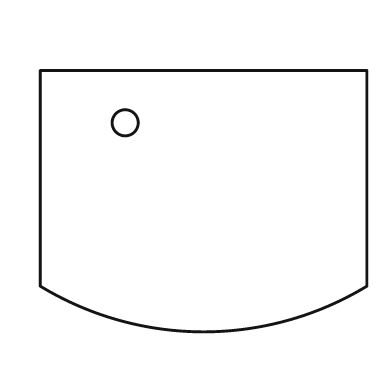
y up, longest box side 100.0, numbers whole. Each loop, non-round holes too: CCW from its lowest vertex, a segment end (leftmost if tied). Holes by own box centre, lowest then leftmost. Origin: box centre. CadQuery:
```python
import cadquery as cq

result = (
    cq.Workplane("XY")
    .moveTo(-50.0, -26.0)
    .threePointArc((0.0, -40.0), (50.0, -26.0))
    .lineTo(50.0, 40.0)
    .lineTo(-50.0, 40.0)
    .close()
    .moveTo(-24.0, 24.0)
    .circle(4.0)
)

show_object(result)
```